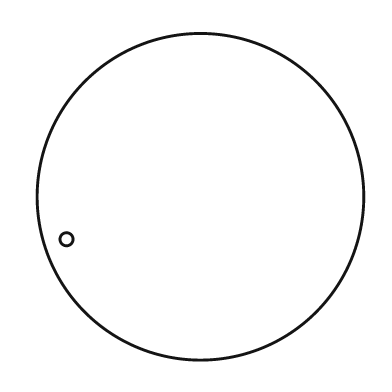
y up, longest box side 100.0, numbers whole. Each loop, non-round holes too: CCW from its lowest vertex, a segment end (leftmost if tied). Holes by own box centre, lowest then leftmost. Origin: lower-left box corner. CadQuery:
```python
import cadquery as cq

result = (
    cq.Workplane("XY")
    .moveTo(50.0, 50.0)
    .circle(50.0)
    .moveTo(9.0, 37.0)
    .circle(2.0)
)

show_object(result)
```